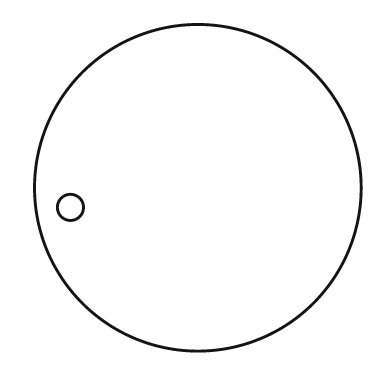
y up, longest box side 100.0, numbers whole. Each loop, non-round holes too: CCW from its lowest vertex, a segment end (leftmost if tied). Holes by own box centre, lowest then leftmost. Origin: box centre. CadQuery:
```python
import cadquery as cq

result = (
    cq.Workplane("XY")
    .moveTo(0.0, 0.0)
    .circle(50.0)
    .moveTo(-39.0, -6.0)
    .circle(4.0)
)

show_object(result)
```